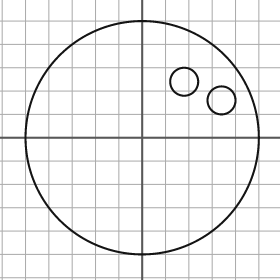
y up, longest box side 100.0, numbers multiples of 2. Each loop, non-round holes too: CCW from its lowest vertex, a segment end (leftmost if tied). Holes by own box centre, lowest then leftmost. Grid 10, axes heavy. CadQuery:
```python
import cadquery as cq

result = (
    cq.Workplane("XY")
    .moveTo(0.0, 0.0)
    .circle(50.0)
    .moveTo(34.0, 16.0)
    .circle(6.0)
    .moveTo(18.0, 24.0)
    .circle(6.0)
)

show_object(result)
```